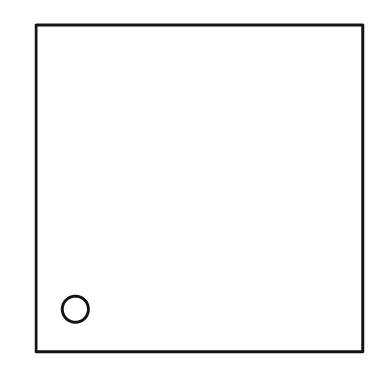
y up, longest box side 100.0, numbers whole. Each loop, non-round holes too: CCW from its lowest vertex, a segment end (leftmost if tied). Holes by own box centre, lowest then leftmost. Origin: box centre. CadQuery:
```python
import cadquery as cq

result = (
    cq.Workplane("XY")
    .moveTo(-50.0, -50.0)
    .lineTo(50.0, -50.0)
    .lineTo(50.0, 50.0)
    .lineTo(-50.0, 50.0)
    .close()
    .moveTo(-38.0, -37.0)
    .circle(4.0)
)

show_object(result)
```